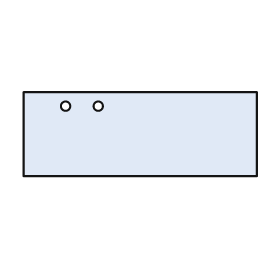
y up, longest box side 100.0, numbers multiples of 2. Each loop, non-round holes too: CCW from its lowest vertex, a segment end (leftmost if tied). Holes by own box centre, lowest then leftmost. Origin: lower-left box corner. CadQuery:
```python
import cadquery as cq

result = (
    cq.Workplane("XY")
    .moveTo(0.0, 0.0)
    .lineTo(100.0, 0.0)
    .lineTo(100.0, 36.0)
    .lineTo(0.0, 36.0)
    .close()
    .moveTo(18.0, 30.0)
    .circle(2.0)
    .moveTo(32.0, 30.0)
    .circle(2.0)
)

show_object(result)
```